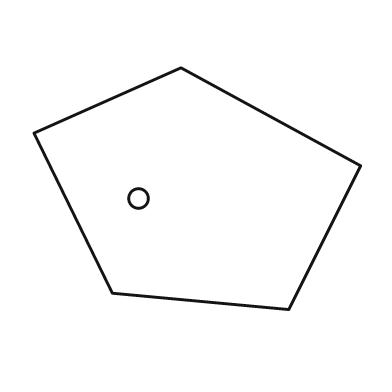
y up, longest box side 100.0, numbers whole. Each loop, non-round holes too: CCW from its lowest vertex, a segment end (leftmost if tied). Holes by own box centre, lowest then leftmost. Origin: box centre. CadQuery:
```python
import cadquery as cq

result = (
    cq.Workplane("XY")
    .moveTo(28.0, -37.0)
    .lineTo(50.0, 7.0)
    .lineTo(-5.0, 37.0)
    .lineTo(-50.0, 17.0)
    .lineTo(-26.0, -32.0)
    .close()
    .moveTo(-18.0, -3.0)
    .circle(3.0)
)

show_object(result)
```